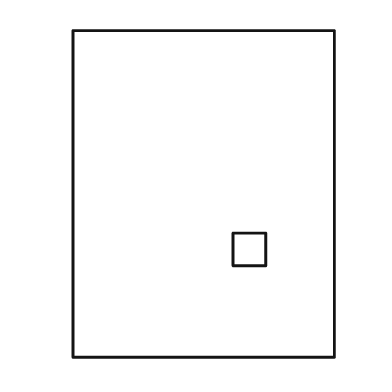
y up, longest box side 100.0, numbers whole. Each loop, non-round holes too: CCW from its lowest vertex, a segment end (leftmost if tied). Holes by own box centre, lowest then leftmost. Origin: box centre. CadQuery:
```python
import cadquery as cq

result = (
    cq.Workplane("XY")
    .moveTo(-40.0, -50.0)
    .lineTo(40.0, -50.0)
    .lineTo(40.0, 50.0)
    .lineTo(-40.0, 50.0)
    .close()
    .moveTo(9.0, -22.0)
    .lineTo(19.0, -22.0)
    .lineTo(19.0, -12.0)
    .lineTo(9.0, -12.0)
    .close()
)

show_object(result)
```